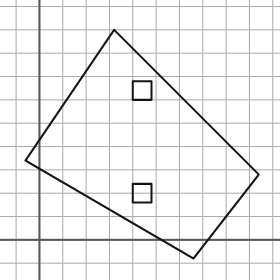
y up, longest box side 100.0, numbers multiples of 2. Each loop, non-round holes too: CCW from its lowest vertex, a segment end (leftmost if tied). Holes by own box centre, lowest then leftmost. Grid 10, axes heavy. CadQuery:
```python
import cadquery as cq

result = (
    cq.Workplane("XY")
    .moveTo(66.0, -8.0)
    .lineTo(94.0, 28.0)
    .lineTo(32.0, 90.0)
    .lineTo(-6.0, 34.0)
    .close()
    .moveTo(40.0, 16.0)
    .lineTo(48.0, 16.0)
    .lineTo(48.0, 24.0)
    .lineTo(40.0, 24.0)
    .close()
    .moveTo(40.0, 60.0)
    .lineTo(48.0, 60.0)
    .lineTo(48.0, 68.0)
    .lineTo(40.0, 68.0)
    .close()
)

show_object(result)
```